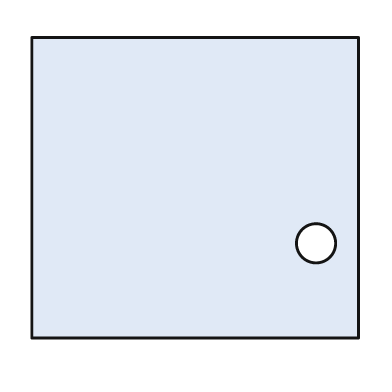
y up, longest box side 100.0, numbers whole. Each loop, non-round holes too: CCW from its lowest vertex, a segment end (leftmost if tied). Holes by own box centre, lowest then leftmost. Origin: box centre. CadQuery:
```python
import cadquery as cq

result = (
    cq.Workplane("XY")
    .moveTo(-50.0, -46.0)
    .lineTo(50.0, -46.0)
    .lineTo(50.0, 46.0)
    .lineTo(-50.0, 46.0)
    .close()
    .moveTo(37.0, -17.0)
    .circle(6.0)
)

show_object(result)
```